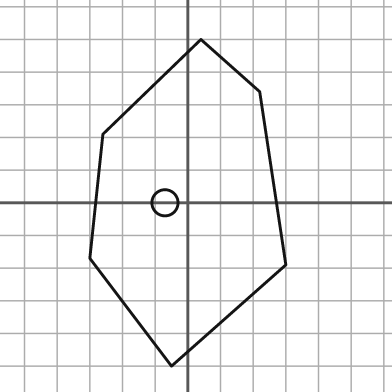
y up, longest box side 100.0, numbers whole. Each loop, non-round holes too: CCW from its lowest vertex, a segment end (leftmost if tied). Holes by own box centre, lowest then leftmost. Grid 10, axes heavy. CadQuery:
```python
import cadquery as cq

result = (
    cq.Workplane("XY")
    .moveTo(-5.0, -50.0)
    .lineTo(30.0, -19.0)
    .lineTo(22.0, 34.0)
    .lineTo(4.0, 50.0)
    .lineTo(-26.0, 21.0)
    .lineTo(-30.0, -17.0)
    .close()
    .moveTo(-7.0, 0.0)
    .circle(4.0)
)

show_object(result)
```